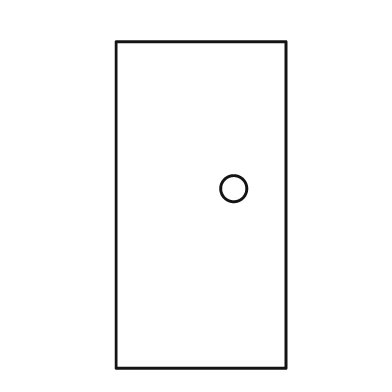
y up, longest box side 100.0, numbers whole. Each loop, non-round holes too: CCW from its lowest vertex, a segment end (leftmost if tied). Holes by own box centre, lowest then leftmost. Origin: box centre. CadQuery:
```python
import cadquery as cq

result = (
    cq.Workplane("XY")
    .moveTo(-26.0, -50.0)
    .lineTo(26.0, -50.0)
    .lineTo(26.0, 50.0)
    .lineTo(-26.0, 50.0)
    .close()
    .moveTo(10.0, 5.0)
    .circle(4.0)
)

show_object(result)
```